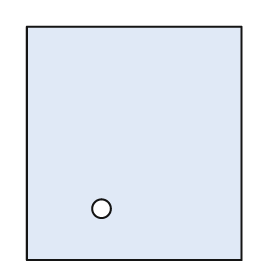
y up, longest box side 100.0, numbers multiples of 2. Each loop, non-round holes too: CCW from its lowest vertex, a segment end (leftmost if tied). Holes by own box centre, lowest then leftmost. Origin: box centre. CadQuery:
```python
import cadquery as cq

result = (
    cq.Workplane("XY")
    .moveTo(-46.0, -50.0)
    .lineTo(46.0, -50.0)
    .lineTo(46.0, 50.0)
    .lineTo(-46.0, 50.0)
    .close()
    .moveTo(-14.0, -28.0)
    .circle(4.0)
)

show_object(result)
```